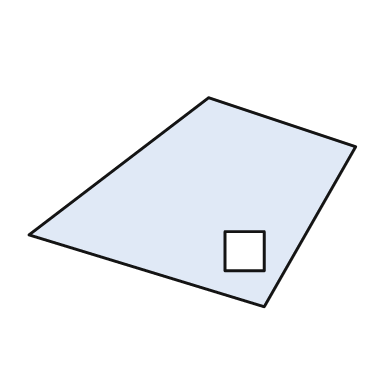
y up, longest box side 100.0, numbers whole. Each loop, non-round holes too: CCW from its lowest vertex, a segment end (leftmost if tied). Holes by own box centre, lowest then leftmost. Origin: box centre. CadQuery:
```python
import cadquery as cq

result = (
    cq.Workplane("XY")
    .moveTo(22.0, -32.0)
    .lineTo(50.0, 17.0)
    .lineTo(5.0, 32.0)
    .lineTo(-50.0, -10.0)
    .close()
    .moveTo(10.0, -21.0)
    .lineTo(22.0, -21.0)
    .lineTo(22.0, -9.0)
    .lineTo(10.0, -9.0)
    .close()
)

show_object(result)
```